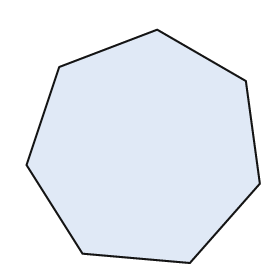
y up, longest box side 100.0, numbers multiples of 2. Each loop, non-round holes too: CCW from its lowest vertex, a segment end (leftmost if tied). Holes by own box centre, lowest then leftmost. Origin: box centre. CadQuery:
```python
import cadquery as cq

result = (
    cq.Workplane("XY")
    .moveTo(20.0, -50.0)
    .lineTo(50.0, -16.0)
    .lineTo(44.0, 28.0)
    .lineTo(6.0, 50.0)
    .lineTo(-36.0, 34.0)
    .lineTo(-50.0, -8.0)
    .lineTo(-26.0, -46.0)
    .close()
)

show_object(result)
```